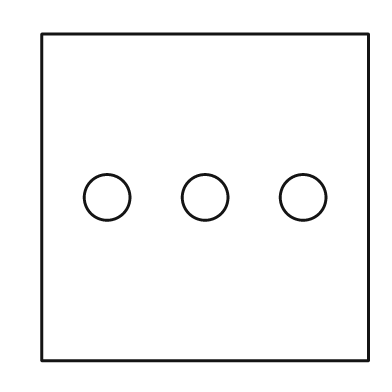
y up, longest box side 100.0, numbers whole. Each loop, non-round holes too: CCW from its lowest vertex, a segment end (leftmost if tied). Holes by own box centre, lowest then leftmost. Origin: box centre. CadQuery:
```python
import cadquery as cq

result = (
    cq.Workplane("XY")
    .moveTo(-50.0, -50.0)
    .lineTo(50.0, -50.0)
    .lineTo(50.0, 50.0)
    .lineTo(-50.0, 50.0)
    .close()
    .moveTo(-30.0, 0.0)
    .circle(7.0)
    .moveTo(0.0, 0.0)
    .circle(7.0)
    .moveTo(30.0, 0.0)
    .circle(7.0)
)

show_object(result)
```